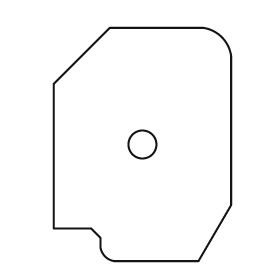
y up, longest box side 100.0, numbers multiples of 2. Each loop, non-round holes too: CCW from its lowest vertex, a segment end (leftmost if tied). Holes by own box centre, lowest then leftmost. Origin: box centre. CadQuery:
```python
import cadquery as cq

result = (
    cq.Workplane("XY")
    .moveTo(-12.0, -50.0)
    .lineTo(24.0, -50.0)
    .lineTo(38.0, -26.0)
    .lineTo(38.0, 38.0)
    .threePointArc((34.0, 46.0), (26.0, 50.0))
    .lineTo(-14.0, 50.0)
    .lineTo(-38.0, 26.0)
    .lineTo(-38.0, -36.0)
    .lineTo(-22.0, -36.0)
    .lineTo(-18.0, -40.0)
    .lineTo(-18.0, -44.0)
    .threePointArc((-16.0, -48.0), (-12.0, -50.0))
    .close()
    .moveTo(0.0, 0.0)
    .circle(6.0)
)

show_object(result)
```